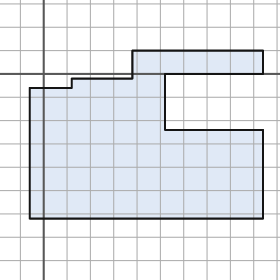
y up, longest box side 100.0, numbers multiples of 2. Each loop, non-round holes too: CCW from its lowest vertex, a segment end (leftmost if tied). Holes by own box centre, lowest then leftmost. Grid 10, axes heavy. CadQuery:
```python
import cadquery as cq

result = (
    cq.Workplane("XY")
    .moveTo(-6.0, -62.0)
    .lineTo(94.0, -62.0)
    .lineTo(94.0, -24.0)
    .lineTo(52.0, -24.0)
    .lineTo(52.0, 0.0)
    .lineTo(94.0, 0.0)
    .lineTo(94.0, 10.0)
    .lineTo(38.0, 10.0)
    .lineTo(38.0, -2.0)
    .lineTo(12.0, -2.0)
    .lineTo(12.0, -6.0)
    .lineTo(-6.0, -6.0)
    .close()
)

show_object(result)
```